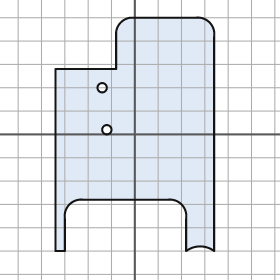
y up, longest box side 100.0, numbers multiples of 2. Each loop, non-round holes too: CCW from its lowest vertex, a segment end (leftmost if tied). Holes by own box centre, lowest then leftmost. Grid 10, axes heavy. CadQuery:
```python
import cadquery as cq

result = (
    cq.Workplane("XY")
    .moveTo(-34.0, -50.0)
    .lineTo(-30.0, -50.0)
    .lineTo(-30.0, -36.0)
    .threePointArc((-28.0, -30.0), (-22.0, -28.0))
    .lineTo(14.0, -28.0)
    .threePointArc((20.0, -30.0), (22.0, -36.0))
    .lineTo(22.0, -50.0)
    .threePointArc((28.0, -48.0), (34.0, -50.0))
    .lineTo(34.0, 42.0)
    .threePointArc((32.0, 48.0), (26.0, 50.0))
    .lineTo(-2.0, 50.0)
    .threePointArc((-6.0, 48.0), (-8.0, 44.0))
    .lineTo(-8.0, 28.0)
    .lineTo(-34.0, 28.0)
    .close()
    .moveTo(-12.0, 2.0)
    .circle(2.0)
    .moveTo(-14.0, 20.0)
    .circle(2.0)
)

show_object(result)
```